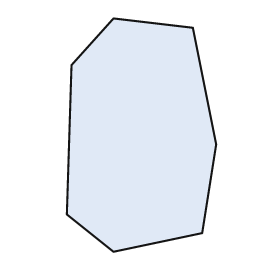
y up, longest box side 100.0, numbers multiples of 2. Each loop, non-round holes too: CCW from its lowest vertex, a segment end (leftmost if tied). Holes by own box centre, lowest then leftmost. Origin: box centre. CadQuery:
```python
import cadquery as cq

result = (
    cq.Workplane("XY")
    .moveTo(-12.0, -50.0)
    .lineTo(26.0, -42.0)
    .lineTo(32.0, -4.0)
    .lineTo(22.0, 46.0)
    .lineTo(-12.0, 50.0)
    .lineTo(-30.0, 30.0)
    .lineTo(-32.0, -34.0)
    .close()
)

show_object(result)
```